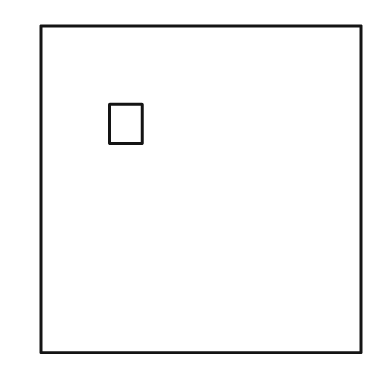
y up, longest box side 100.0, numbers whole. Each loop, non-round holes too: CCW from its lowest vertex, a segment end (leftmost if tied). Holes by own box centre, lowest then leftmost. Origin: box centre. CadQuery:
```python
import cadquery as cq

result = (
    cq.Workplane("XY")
    .moveTo(-49.0, -50.0)
    .lineTo(49.0, -50.0)
    .lineTo(49.0, 50.0)
    .lineTo(-49.0, 50.0)
    .close()
    .moveTo(-28.0, 14.0)
    .lineTo(-18.0, 14.0)
    .lineTo(-18.0, 26.0)
    .lineTo(-28.0, 26.0)
    .close()
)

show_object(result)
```